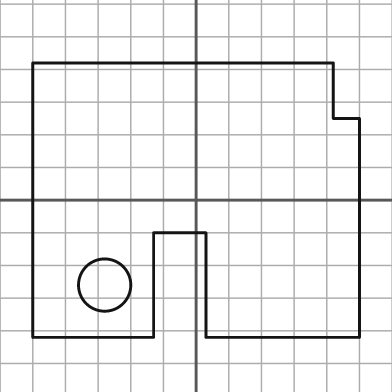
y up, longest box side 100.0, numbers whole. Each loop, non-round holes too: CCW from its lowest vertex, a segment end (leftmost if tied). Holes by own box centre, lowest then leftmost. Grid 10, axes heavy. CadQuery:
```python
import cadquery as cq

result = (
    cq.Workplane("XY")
    .moveTo(-50.0, -42.0)
    .lineTo(-13.0, -42.0)
    .lineTo(-13.0, -10.0)
    .lineTo(3.0, -10.0)
    .lineTo(3.0, -42.0)
    .lineTo(50.0, -42.0)
    .lineTo(50.0, 25.0)
    .lineTo(42.0, 25.0)
    .lineTo(42.0, 42.0)
    .lineTo(-50.0, 42.0)
    .close()
    .moveTo(-28.0, -26.0)
    .circle(8.0)
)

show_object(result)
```